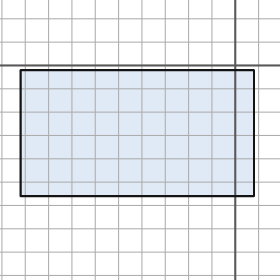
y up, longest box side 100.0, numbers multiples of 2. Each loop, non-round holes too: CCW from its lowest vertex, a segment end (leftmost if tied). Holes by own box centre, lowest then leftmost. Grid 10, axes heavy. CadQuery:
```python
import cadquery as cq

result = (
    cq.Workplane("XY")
    .moveTo(-92.0, -56.0)
    .lineTo(8.0, -56.0)
    .lineTo(8.0, -2.0)
    .lineTo(-92.0, -2.0)
    .close()
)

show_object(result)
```